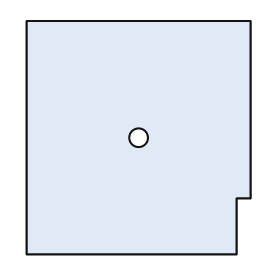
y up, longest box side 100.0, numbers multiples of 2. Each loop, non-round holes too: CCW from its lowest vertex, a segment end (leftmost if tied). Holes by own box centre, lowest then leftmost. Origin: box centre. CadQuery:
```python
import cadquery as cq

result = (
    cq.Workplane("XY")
    .moveTo(-48.0, -50.0)
    .lineTo(42.0, -50.0)
    .lineTo(42.0, -26.0)
    .lineTo(48.0, -26.0)
    .lineTo(48.0, 50.0)
    .lineTo(-48.0, 50.0)
    .close()
    .moveTo(0.0, 0.0)
    .circle(4.0)
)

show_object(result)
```